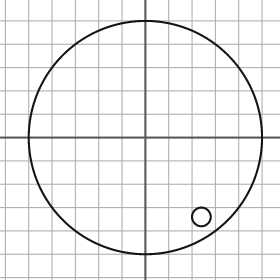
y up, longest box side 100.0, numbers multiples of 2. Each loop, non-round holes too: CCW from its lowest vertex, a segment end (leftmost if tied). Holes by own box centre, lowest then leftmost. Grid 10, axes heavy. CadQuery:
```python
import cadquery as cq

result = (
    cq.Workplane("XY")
    .moveTo(0.0, 0.0)
    .circle(50.0)
    .moveTo(24.0, -34.0)
    .circle(4.0)
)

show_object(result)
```